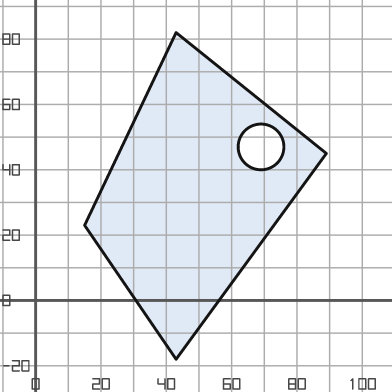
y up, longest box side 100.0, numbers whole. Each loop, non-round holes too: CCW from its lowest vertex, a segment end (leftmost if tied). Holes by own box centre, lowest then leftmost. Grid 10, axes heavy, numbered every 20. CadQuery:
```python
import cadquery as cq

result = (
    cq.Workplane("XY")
    .moveTo(43.0, -18.0)
    .lineTo(89.0, 45.0)
    .lineTo(43.0, 82.0)
    .lineTo(15.0, 23.0)
    .close()
    .moveTo(69.0, 47.0)
    .circle(7.0)
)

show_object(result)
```